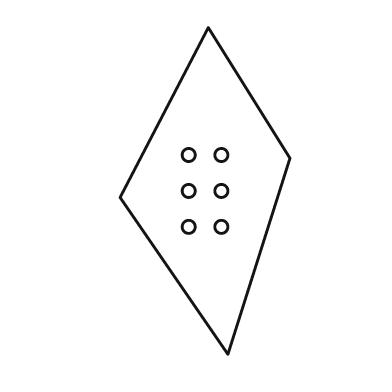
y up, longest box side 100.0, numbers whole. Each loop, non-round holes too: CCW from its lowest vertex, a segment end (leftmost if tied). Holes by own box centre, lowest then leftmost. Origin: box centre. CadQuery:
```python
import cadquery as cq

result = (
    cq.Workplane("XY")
    .moveTo(7.0, -50.0)
    .lineTo(26.0, 10.0)
    .lineTo(1.0, 50.0)
    .lineTo(-26.0, -2.0)
    .close()
    .moveTo(-5.0, -11.0)
    .circle(2.0)
    .moveTo(5.0, -11.0)
    .circle(2.0)
    .moveTo(-5.0, 0.0)
    .circle(2.0)
    .moveTo(5.0, 0.0)
    .circle(2.0)
    .moveTo(-5.0, 11.0)
    .circle(2.0)
    .moveTo(5.0, 11.0)
    .circle(2.0)
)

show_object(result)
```